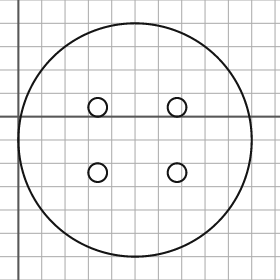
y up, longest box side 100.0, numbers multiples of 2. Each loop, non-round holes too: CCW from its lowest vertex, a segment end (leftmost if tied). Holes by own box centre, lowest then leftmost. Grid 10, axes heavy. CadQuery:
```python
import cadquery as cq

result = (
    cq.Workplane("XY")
    .moveTo(50.0, -10.0)
    .circle(50.0)
    .moveTo(34.0, -24.0)
    .circle(4.0)
    .moveTo(68.0, -24.0)
    .circle(4.0)
    .moveTo(34.0, 4.0)
    .circle(4.0)
    .moveTo(68.0, 4.0)
    .circle(4.0)
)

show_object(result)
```